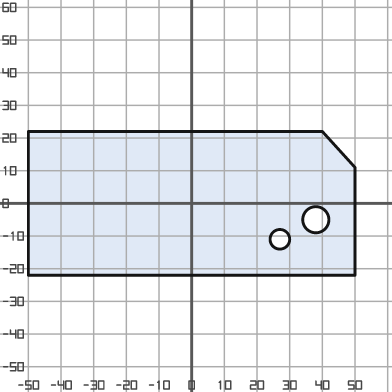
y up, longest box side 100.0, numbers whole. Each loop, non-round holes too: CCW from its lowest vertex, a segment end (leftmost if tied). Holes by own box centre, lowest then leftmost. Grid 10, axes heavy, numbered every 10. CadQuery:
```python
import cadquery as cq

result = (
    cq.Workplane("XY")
    .moveTo(-50.0, -22.0)
    .lineTo(50.0, -22.0)
    .lineTo(50.0, 11.0)
    .lineTo(40.0, 22.0)
    .lineTo(-50.0, 22.0)
    .close()
    .moveTo(27.0, -11.0)
    .circle(3.0)
    .moveTo(38.0, -5.0)
    .circle(4.0)
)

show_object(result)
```